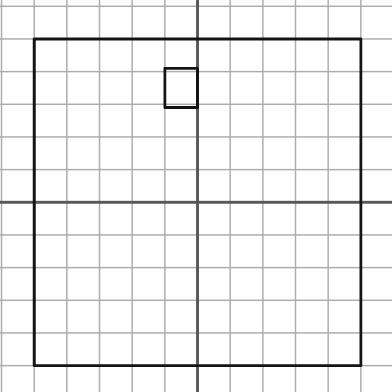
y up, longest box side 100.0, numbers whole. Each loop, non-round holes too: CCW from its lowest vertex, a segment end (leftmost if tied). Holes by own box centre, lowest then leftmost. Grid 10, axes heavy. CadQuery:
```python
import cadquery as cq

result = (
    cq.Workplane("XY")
    .moveTo(-50.0, -50.0)
    .lineTo(50.0, -50.0)
    .lineTo(50.0, 50.0)
    .lineTo(-50.0, 50.0)
    .close()
    .moveTo(-10.0, 29.0)
    .lineTo(0.0, 29.0)
    .lineTo(0.0, 41.0)
    .lineTo(-10.0, 41.0)
    .close()
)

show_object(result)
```